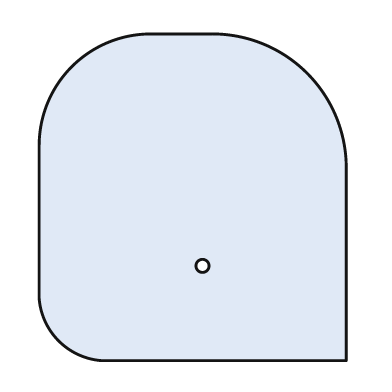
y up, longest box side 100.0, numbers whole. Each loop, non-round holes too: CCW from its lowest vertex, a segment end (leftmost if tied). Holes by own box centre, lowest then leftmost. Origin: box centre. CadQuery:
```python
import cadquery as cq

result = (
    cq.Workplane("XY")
    .moveTo(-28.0, -50.0)
    .lineTo(47.0, -50.0)
    .lineTo(47.0, 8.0)
    .threePointArc((35.0, 38.0), (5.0, 50.0))
    .lineTo(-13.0, 50.0)
    .threePointArc((-37.0, 40.0), (-47.0, 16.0))
    .lineTo(-47.0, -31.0)
    .threePointArc((-41.0, -44.0), (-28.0, -50.0))
    .close()
    .moveTo(3.0, -21.0)
    .circle(2.0)
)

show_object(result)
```